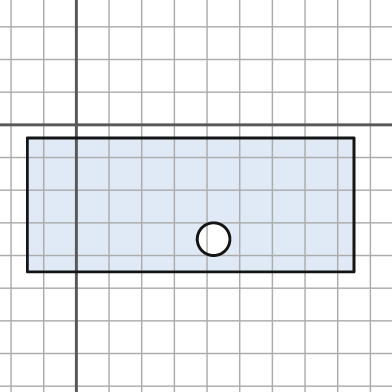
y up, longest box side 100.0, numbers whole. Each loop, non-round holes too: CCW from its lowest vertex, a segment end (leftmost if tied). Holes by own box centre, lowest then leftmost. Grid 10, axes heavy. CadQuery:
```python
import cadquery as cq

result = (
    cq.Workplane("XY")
    .moveTo(-15.0, -45.0)
    .lineTo(85.0, -45.0)
    .lineTo(85.0, -4.0)
    .lineTo(-15.0, -4.0)
    .close()
    .moveTo(42.0, -35.0)
    .circle(5.0)
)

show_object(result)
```